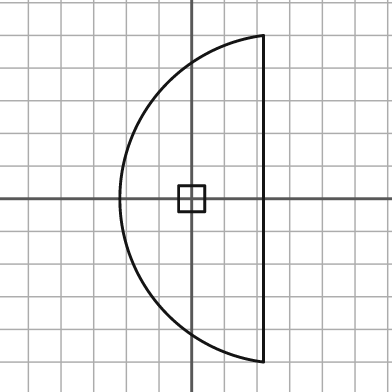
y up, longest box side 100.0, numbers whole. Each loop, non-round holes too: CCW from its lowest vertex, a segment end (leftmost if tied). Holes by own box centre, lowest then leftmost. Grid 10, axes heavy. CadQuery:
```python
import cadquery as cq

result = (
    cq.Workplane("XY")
    .moveTo(22.0, -50.0)
    .lineTo(22.0, 50.0)
    .threePointArc((-22.0, 0.0), (22.0, -50.0))
    .close()
    .moveTo(-4.0, -4.0)
    .lineTo(4.0, -4.0)
    .lineTo(4.0, 4.0)
    .lineTo(-4.0, 4.0)
    .close()
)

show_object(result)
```